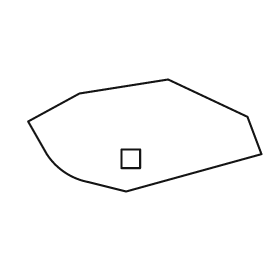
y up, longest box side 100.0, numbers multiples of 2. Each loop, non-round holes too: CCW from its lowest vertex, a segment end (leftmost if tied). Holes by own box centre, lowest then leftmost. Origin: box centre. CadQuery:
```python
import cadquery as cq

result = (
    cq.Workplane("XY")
    .moveTo(-8.0, -24.0)
    .lineTo(50.0, -8.0)
    .lineTo(44.0, 8.0)
    .lineTo(10.0, 24.0)
    .lineTo(-28.0, 18.0)
    .lineTo(-50.0, 6.0)
    .lineTo(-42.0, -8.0)
    .threePointArc((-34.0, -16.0), (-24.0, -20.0))
    .close()
    .moveTo(-10.0, -14.0)
    .lineTo(-2.0, -14.0)
    .lineTo(-2.0, -6.0)
    .lineTo(-10.0, -6.0)
    .close()
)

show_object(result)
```